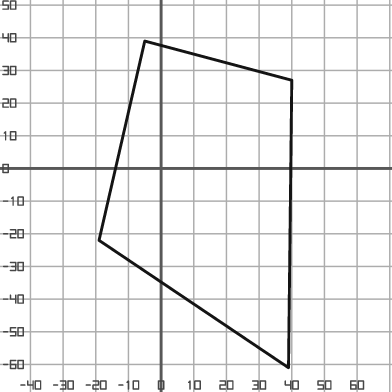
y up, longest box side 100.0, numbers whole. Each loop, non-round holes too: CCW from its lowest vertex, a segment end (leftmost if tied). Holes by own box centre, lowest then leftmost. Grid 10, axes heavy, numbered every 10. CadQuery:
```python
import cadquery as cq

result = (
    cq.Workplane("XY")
    .moveTo(39.0, -61.0)
    .lineTo(40.0, 27.0)
    .lineTo(-5.0, 39.0)
    .lineTo(-19.0, -22.0)
    .close()
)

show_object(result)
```